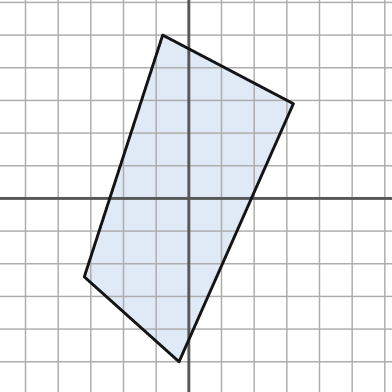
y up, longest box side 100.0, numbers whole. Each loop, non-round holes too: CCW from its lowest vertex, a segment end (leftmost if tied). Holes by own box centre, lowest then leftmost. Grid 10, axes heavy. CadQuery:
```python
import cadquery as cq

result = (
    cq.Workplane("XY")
    .moveTo(-3.0, -50.0)
    .lineTo(32.0, 29.0)
    .lineTo(-8.0, 50.0)
    .lineTo(-32.0, -24.0)
    .close()
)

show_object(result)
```